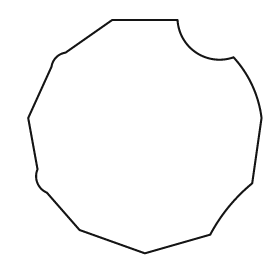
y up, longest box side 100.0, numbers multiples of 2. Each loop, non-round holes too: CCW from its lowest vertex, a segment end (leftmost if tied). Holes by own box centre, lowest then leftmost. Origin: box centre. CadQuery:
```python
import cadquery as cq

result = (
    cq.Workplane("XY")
    .moveTo(0.0, -50.0)
    .lineTo(28.0, -42.0)
    .threePointArc((36.0, -30.0), (46.0, -20.0))
    .lineTo(50.0, 8.0)
    .threePointArc((46.0, 22.0), (38.0, 34.0))
    .threePointArc((22.0, 36.0), (14.0, 50.0))
    .lineTo(-14.0, 50.0)
    .lineTo(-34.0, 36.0)
    .threePointArc((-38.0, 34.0), (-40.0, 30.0))
    .lineTo(-50.0, 8.0)
    .lineTo(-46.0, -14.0)
    .threePointArc((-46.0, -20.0), (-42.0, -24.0))
    .lineTo(-28.0, -40.0)
    .close()
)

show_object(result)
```